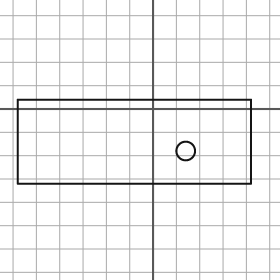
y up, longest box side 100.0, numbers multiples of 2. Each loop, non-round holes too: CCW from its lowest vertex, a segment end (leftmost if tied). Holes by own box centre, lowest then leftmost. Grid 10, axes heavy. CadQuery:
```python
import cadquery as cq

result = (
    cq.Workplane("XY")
    .moveTo(-58.0, -32.0)
    .lineTo(42.0, -32.0)
    .lineTo(42.0, 4.0)
    .lineTo(-58.0, 4.0)
    .close()
    .moveTo(14.0, -18.0)
    .circle(4.0)
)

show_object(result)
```